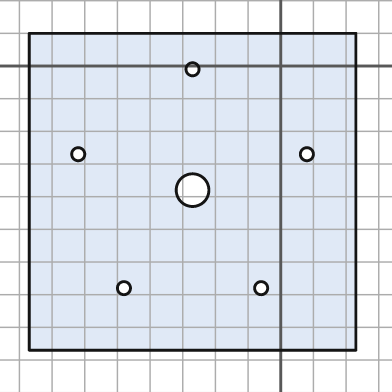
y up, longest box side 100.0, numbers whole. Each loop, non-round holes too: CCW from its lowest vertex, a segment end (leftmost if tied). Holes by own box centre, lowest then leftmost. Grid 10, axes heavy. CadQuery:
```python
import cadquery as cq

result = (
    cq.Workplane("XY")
    .moveTo(-77.0, -87.0)
    .lineTo(23.0, -87.0)
    .lineTo(23.0, 10.0)
    .lineTo(-77.0, 10.0)
    .close()
    .moveTo(-48.0, -68.0)
    .circle(2.0)
    .moveTo(-6.0, -68.0)
    .circle(2.0)
    .moveTo(-27.0, -38.0)
    .circle(5.0)
    .moveTo(-62.0, -27.0)
    .circle(2.0)
    .moveTo(8.0, -27.0)
    .circle(2.0)
    .moveTo(-27.0, -1.0)
    .circle(2.0)
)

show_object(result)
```